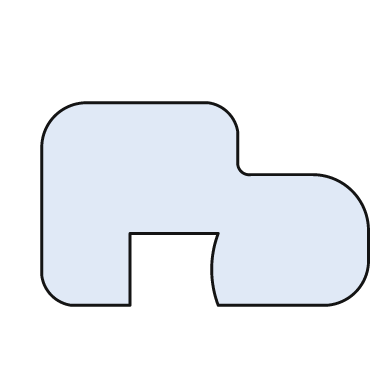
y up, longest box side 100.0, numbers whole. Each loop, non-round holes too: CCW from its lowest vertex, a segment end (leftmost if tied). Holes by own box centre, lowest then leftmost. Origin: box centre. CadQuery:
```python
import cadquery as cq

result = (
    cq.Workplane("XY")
    .moveTo(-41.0, -31.0)
    .lineTo(-23.0, -31.0)
    .lineTo(-23.0, -9.0)
    .lineTo(4.0, -9.0)
    .threePointArc((2.0, -20.0), (4.0, -31.0))
    .lineTo(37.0, -31.0)
    .threePointArc((46.0, -27.0), (50.0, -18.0))
    .lineTo(50.0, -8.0)
    .threePointArc((45.0, 4.0), (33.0, 9.0))
    .lineTo(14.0, 9.0)
    .threePointArc((11.0, 10.0), (10.0, 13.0))
    .lineTo(10.0, 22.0)
    .threePointArc((7.0, 28.0), (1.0, 31.0))
    .lineTo(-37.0, 31.0)
    .threePointArc((-46.0, 27.0), (-50.0, 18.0))
    .lineTo(-50.0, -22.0)
    .threePointArc((-47.0, -28.0), (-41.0, -31.0))
    .close()
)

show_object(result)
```